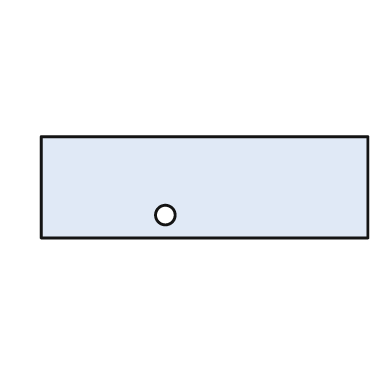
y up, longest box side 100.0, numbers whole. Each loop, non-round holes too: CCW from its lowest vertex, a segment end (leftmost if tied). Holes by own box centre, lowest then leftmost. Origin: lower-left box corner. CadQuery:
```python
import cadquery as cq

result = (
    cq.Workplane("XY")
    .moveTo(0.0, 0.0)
    .lineTo(100.0, 0.0)
    .lineTo(100.0, 31.0)
    .lineTo(0.0, 31.0)
    .close()
    .moveTo(38.0, 7.0)
    .circle(3.0)
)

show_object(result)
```